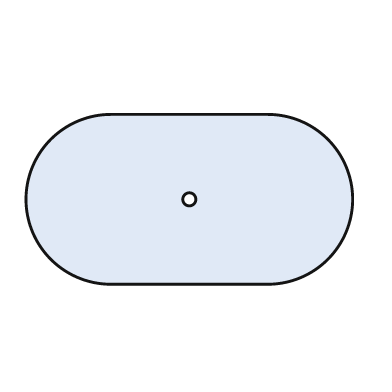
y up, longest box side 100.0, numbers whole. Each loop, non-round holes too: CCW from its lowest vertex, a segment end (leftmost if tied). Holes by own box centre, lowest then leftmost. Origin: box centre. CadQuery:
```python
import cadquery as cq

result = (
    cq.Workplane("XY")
    .moveTo(-24.0, -26.0)
    .lineTo(24.0, -26.0)
    .threePointArc((50.0, 0.0), (24.0, 26.0))
    .lineTo(-24.0, 26.0)
    .threePointArc((-50.0, 0.0), (-24.0, -26.0))
    .close()
    .moveTo(0.0, 0.0)
    .circle(2.0)
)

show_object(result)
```